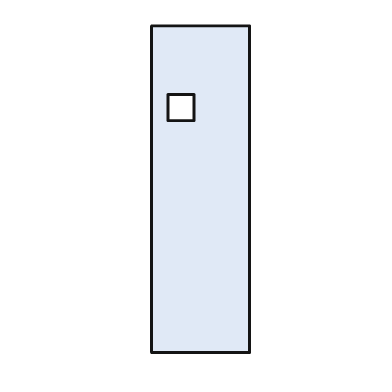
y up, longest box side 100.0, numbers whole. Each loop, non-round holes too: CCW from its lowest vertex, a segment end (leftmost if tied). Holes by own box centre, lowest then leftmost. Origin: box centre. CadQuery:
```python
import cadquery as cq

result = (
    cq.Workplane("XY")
    .moveTo(-15.0, -50.0)
    .lineTo(15.0, -50.0)
    .lineTo(15.0, 50.0)
    .lineTo(-15.0, 50.0)
    .close()
    .moveTo(-10.0, 21.0)
    .lineTo(-2.0, 21.0)
    .lineTo(-2.0, 29.0)
    .lineTo(-10.0, 29.0)
    .close()
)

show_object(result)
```